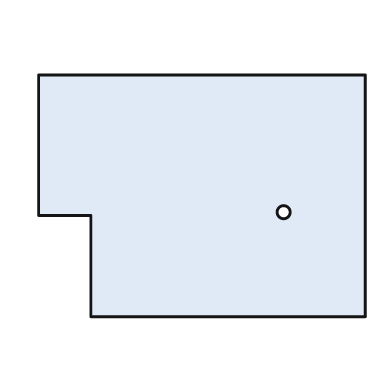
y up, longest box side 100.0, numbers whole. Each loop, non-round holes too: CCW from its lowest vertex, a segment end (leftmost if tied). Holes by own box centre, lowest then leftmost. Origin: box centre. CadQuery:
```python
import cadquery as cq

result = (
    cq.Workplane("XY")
    .moveTo(-34.0, -37.0)
    .lineTo(50.0, -37.0)
    .lineTo(50.0, 37.0)
    .lineTo(-50.0, 37.0)
    .lineTo(-50.0, -6.0)
    .lineTo(-34.0, -6.0)
    .close()
    .moveTo(25.0, -5.0)
    .circle(2.0)
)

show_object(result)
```